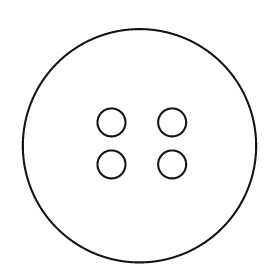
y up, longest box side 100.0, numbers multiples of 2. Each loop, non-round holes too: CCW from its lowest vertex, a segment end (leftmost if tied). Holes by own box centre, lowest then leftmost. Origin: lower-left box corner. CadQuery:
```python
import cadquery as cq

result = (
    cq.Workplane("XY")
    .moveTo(50.0, 50.0)
    .circle(50.0)
    .moveTo(38.0, 42.0)
    .circle(6.0)
    .moveTo(64.0, 42.0)
    .circle(6.0)
    .moveTo(38.0, 60.0)
    .circle(6.0)
    .moveTo(64.0, 60.0)
    .circle(6.0)
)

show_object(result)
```